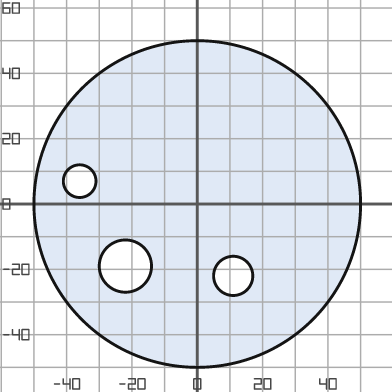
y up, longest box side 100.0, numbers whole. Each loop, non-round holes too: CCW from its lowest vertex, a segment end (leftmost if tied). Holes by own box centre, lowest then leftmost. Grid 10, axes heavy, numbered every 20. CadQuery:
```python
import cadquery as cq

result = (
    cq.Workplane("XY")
    .moveTo(0.0, 0.0)
    .circle(50.0)
    .moveTo(11.0, -22.0)
    .circle(6.0)
    .moveTo(-22.0, -19.0)
    .circle(8.0)
    .moveTo(-36.0, 7.0)
    .circle(5.0)
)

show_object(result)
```